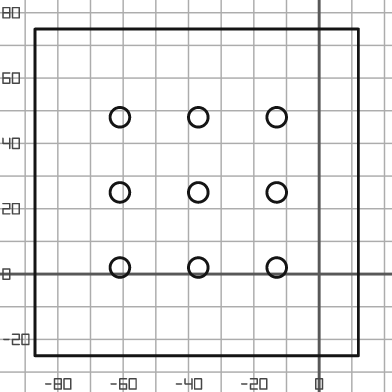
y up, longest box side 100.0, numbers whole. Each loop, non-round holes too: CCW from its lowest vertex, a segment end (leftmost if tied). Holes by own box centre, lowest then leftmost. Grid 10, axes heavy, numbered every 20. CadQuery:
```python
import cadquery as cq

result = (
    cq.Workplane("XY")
    .moveTo(-87.0, -25.0)
    .lineTo(12.0, -25.0)
    .lineTo(12.0, 75.0)
    .lineTo(-87.0, 75.0)
    .close()
    .moveTo(-61.0, 2.0)
    .circle(3.0)
    .moveTo(-37.0, 2.0)
    .circle(3.0)
    .moveTo(-13.0, 2.0)
    .circle(3.0)
    .moveTo(-61.0, 25.0)
    .circle(3.0)
    .moveTo(-37.0, 25.0)
    .circle(3.0)
    .moveTo(-13.0, 25.0)
    .circle(3.0)
    .moveTo(-61.0, 48.0)
    .circle(3.0)
    .moveTo(-37.0, 48.0)
    .circle(3.0)
    .moveTo(-13.0, 48.0)
    .circle(3.0)
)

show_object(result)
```